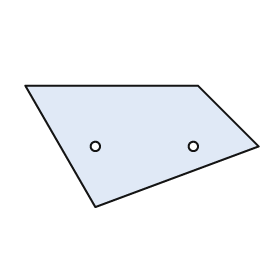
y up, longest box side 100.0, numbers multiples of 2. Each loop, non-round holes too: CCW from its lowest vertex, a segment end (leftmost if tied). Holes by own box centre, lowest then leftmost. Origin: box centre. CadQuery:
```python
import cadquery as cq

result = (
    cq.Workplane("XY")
    .moveTo(-20.0, -26.0)
    .lineTo(50.0, 0.0)
    .lineTo(24.0, 26.0)
    .lineTo(-50.0, 26.0)
    .close()
    .moveTo(-20.0, 0.0)
    .circle(2.0)
    .moveTo(22.0, 0.0)
    .circle(2.0)
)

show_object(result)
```